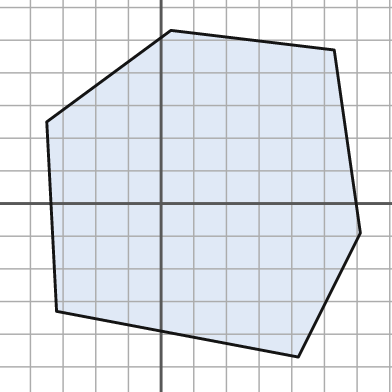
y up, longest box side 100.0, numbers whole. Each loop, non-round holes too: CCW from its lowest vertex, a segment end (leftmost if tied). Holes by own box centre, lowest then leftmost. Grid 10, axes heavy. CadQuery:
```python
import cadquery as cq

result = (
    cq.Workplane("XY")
    .moveTo(42.0, -47.0)
    .lineTo(61.0, -9.0)
    .lineTo(53.0, 47.0)
    .lineTo(3.0, 53.0)
    .lineTo(-35.0, 25.0)
    .lineTo(-32.0, -33.0)
    .close()
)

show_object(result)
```